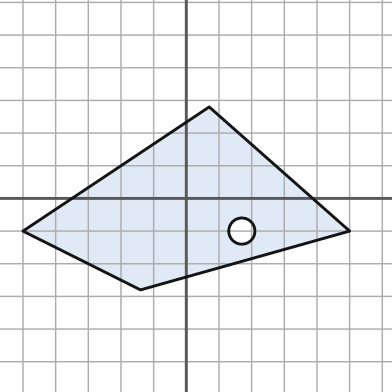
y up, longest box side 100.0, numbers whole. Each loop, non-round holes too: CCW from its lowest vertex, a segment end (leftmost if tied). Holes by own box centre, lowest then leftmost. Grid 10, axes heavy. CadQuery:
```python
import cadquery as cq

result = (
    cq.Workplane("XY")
    .moveTo(-14.0, -28.0)
    .lineTo(50.0, -10.0)
    .lineTo(7.0, 28.0)
    .lineTo(-50.0, -10.0)
    .close()
    .moveTo(17.0, -10.0)
    .circle(4.0)
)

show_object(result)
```